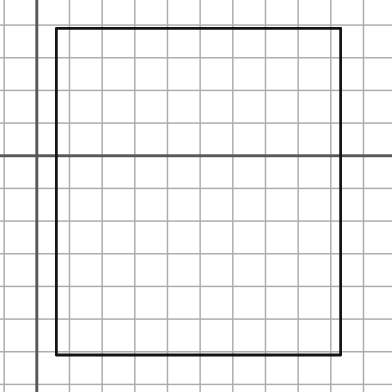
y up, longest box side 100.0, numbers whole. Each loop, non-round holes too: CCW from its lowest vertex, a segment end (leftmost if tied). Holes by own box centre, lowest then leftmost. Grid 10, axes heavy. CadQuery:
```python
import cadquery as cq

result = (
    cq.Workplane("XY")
    .moveTo(6.0, -61.0)
    .lineTo(93.0, -61.0)
    .lineTo(93.0, 39.0)
    .lineTo(6.0, 39.0)
    .close()
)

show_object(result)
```